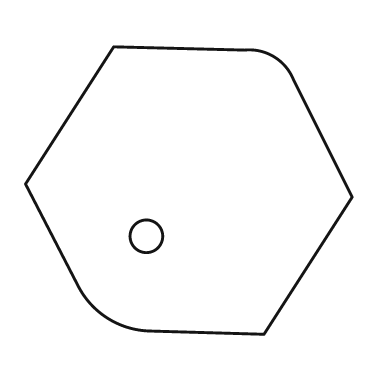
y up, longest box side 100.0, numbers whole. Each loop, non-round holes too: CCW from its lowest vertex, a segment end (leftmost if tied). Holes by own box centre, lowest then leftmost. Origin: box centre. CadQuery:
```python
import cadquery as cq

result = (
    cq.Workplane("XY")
    .moveTo(23.0, -44.0)
    .lineTo(50.0, -2.0)
    .lineTo(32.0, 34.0)
    .threePointArc((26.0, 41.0), (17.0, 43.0))
    .lineTo(-23.0, 44.0)
    .lineTo(-50.0, 2.0)
    .lineTo(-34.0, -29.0)
    .threePointArc((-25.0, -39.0), (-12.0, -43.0))
    .close()
    .moveTo(-13.0, -14.0)
    .circle(5.0)
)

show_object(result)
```